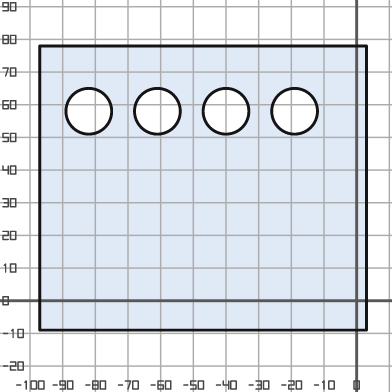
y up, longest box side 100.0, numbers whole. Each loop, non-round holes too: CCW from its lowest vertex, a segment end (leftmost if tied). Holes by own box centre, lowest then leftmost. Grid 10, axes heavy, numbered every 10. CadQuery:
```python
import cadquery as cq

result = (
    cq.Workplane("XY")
    .moveTo(-97.0, -9.0)
    .lineTo(3.0, -9.0)
    .lineTo(3.0, 78.0)
    .lineTo(-97.0, 78.0)
    .close()
    .moveTo(-82.0, 58.0)
    .circle(7.0)
    .moveTo(-61.0, 58.0)
    .circle(7.0)
    .moveTo(-40.0, 58.0)
    .circle(7.0)
    .moveTo(-19.0, 58.0)
    .circle(7.0)
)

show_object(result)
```